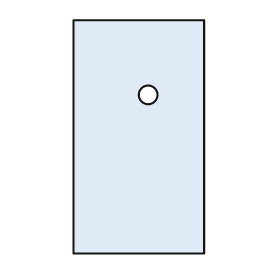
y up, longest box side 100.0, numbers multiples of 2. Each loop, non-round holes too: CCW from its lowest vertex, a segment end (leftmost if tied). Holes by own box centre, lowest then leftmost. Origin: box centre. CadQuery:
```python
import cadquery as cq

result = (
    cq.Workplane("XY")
    .moveTo(-28.0, -50.0)
    .lineTo(28.0, -50.0)
    .lineTo(28.0, 50.0)
    .lineTo(-28.0, 50.0)
    .close()
    .moveTo(4.0, 18.0)
    .circle(4.0)
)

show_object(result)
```